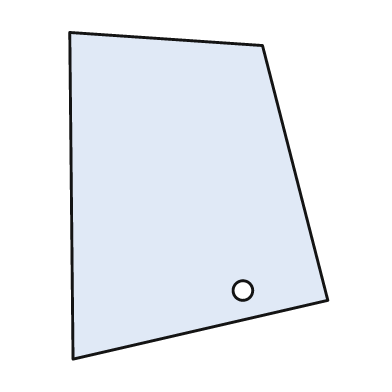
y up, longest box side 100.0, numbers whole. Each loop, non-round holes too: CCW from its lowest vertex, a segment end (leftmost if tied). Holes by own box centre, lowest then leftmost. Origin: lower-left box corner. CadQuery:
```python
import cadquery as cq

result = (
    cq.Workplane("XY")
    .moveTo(1.0, 0.0)
    .lineTo(79.0, 18.0)
    .lineTo(59.0, 96.0)
    .lineTo(0.0, 100.0)
    .close()
    .moveTo(53.0, 21.0)
    .circle(3.0)
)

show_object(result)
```